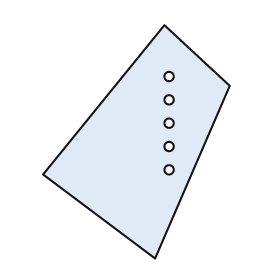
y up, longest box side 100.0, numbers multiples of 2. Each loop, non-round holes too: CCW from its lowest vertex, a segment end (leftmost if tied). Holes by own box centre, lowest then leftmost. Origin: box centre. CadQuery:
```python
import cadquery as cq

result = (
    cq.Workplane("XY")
    .moveTo(8.0, -50.0)
    .lineTo(40.0, 24.0)
    .lineTo(12.0, 50.0)
    .lineTo(-40.0, -14.0)
    .close()
    .moveTo(14.0, -12.0)
    .circle(2.0)
    .moveTo(14.0, -2.0)
    .circle(2.0)
    .moveTo(14.0, 8.0)
    .circle(2.0)
    .moveTo(14.0, 18.0)
    .circle(2.0)
    .moveTo(14.0, 28.0)
    .circle(2.0)
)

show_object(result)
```